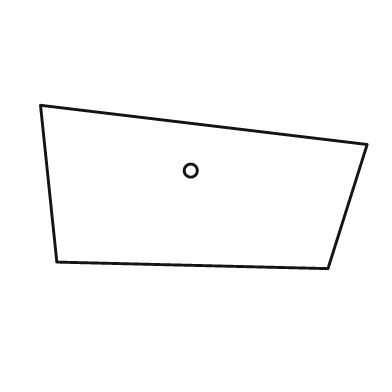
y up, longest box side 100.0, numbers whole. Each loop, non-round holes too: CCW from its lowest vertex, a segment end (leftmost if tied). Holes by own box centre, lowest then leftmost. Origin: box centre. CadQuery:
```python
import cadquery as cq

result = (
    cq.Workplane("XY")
    .moveTo(38.0, -25.0)
    .lineTo(50.0, 13.0)
    .lineTo(-50.0, 25.0)
    .lineTo(-45.0, -23.0)
    .close()
    .moveTo(-4.0, 5.0)
    .circle(2.0)
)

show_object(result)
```